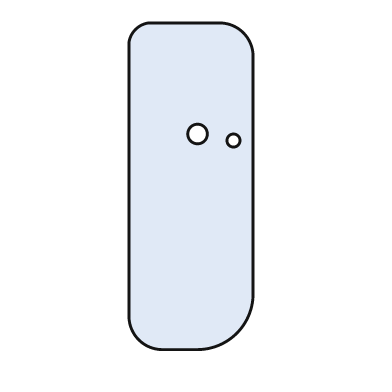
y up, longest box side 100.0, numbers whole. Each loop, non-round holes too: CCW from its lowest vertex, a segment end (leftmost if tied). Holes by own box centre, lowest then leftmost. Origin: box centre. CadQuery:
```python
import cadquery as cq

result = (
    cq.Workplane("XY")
    .moveTo(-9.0, -50.0)
    .lineTo(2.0, -50.0)
    .threePointArc((14.0, -45.0), (19.0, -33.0))
    .lineTo(19.0, 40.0)
    .threePointArc((16.0, 47.0), (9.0, 50.0))
    .lineTo(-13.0, 50.0)
    .threePointArc((-17.0, 48.0), (-19.0, 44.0))
    .lineTo(-19.0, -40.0)
    .threePointArc((-16.0, -47.0), (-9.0, -50.0))
    .close()
    .moveTo(13.0, 14.0)
    .circle(2.0)
    .moveTo(2.0, 16.0)
    .circle(3.0)
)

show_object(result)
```